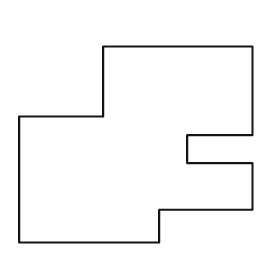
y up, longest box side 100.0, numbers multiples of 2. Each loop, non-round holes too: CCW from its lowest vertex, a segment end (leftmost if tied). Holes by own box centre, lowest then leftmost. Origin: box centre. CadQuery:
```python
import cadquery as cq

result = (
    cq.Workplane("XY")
    .moveTo(-50.0, -42.0)
    .lineTo(10.0, -42.0)
    .lineTo(10.0, -28.0)
    .lineTo(50.0, -28.0)
    .lineTo(50.0, -8.0)
    .lineTo(22.0, -8.0)
    .lineTo(22.0, 4.0)
    .lineTo(50.0, 4.0)
    .lineTo(50.0, 42.0)
    .lineTo(-14.0, 42.0)
    .lineTo(-14.0, 12.0)
    .lineTo(-50.0, 12.0)
    .close()
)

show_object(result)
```